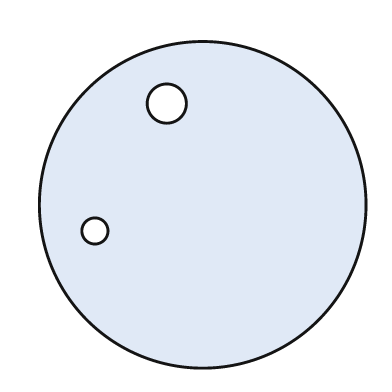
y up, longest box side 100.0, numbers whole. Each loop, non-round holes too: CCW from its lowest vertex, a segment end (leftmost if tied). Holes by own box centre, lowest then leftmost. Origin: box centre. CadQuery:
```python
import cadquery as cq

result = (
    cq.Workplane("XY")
    .moveTo(0.0, 0.0)
    .circle(50.0)
    .moveTo(-33.0, -8.0)
    .circle(4.0)
    .moveTo(-11.0, 31.0)
    .circle(6.0)
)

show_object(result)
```